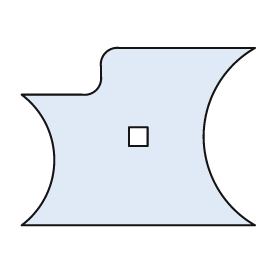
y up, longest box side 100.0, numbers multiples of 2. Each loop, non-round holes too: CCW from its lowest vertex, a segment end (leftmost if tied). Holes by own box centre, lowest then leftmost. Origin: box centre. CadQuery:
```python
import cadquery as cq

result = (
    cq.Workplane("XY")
    .moveTo(-50.0, -38.0)
    .lineTo(50.0, -38.0)
    .threePointArc((28.0, 0.0), (50.0, 38.0))
    .lineTo(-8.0, 38.0)
    .threePointArc((-14.0, 36.0), (-16.0, 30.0))
    .lineTo(-16.0, 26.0)
    .threePointArc((-18.0, 20.0), (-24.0, 18.0))
    .lineTo(-50.0, 18.0)
    .threePointArc((-36.0, -10.0), (-50.0, -38.0))
    .close()
    .moveTo(-4.0, -4.0)
    .lineTo(4.0, -4.0)
    .lineTo(4.0, 4.0)
    .lineTo(-4.0, 4.0)
    .close()
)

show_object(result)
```